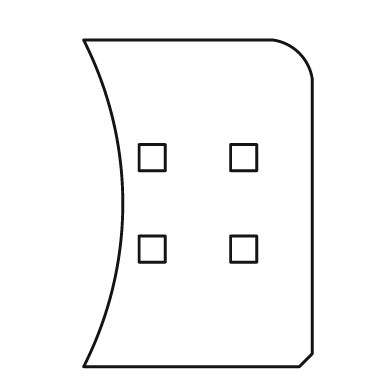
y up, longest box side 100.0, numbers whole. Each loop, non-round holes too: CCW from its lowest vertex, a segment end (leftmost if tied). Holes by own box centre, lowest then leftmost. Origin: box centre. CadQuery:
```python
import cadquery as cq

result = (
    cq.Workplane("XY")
    .moveTo(-35.0, -50.0)
    .lineTo(31.0, -50.0)
    .lineTo(35.0, -46.0)
    .lineTo(35.0, 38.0)
    .threePointArc((31.0, 46.0), (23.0, 50.0))
    .lineTo(-35.0, 50.0)
    .threePointArc((-23.0, 0.0), (-35.0, -50.0))
    .close()
    .moveTo(-18.0, -18.0)
    .lineTo(-10.0, -18.0)
    .lineTo(-10.0, -10.0)
    .lineTo(-18.0, -10.0)
    .close()
    .moveTo(10.0, -18.0)
    .lineTo(18.0, -18.0)
    .lineTo(18.0, -10.0)
    .lineTo(10.0, -10.0)
    .close()
    .moveTo(-18.0, 10.0)
    .lineTo(-10.0, 10.0)
    .lineTo(-10.0, 18.0)
    .lineTo(-18.0, 18.0)
    .close()
    .moveTo(10.0, 10.0)
    .lineTo(18.0, 10.0)
    .lineTo(18.0, 18.0)
    .lineTo(10.0, 18.0)
    .close()
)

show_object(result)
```